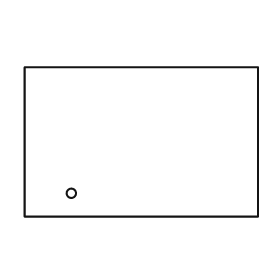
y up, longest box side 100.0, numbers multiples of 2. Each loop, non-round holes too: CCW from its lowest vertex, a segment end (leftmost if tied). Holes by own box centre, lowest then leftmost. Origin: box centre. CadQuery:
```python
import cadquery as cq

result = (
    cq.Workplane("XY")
    .moveTo(-50.0, -32.0)
    .lineTo(50.0, -32.0)
    .lineTo(50.0, 32.0)
    .lineTo(-50.0, 32.0)
    .close()
    .moveTo(-30.0, -22.0)
    .circle(2.0)
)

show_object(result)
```